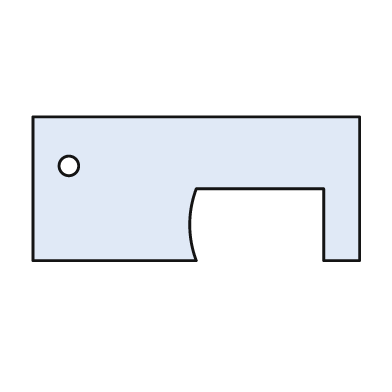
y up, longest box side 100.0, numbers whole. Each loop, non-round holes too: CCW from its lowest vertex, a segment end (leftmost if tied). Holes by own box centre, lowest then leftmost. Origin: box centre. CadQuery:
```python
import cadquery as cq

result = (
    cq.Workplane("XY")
    .moveTo(-50.0, -22.0)
    .lineTo(0.0, -22.0)
    .threePointArc((-2.0, -11.0), (0.0, 0.0))
    .lineTo(39.0, 0.0)
    .lineTo(39.0, -22.0)
    .lineTo(50.0, -22.0)
    .lineTo(50.0, 22.0)
    .lineTo(-50.0, 22.0)
    .close()
    .moveTo(-39.0, 7.0)
    .circle(3.0)
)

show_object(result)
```